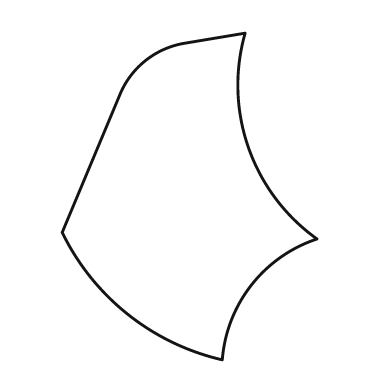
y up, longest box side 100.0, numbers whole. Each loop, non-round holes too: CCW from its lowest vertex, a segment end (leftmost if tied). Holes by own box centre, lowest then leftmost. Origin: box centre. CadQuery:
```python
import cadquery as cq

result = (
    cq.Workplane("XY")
    .moveTo(10.0, -50.0)
    .threePointArc((19.0, -27.0), (39.0, -13.0))
    .threePointArc((18.0, 15.0), (17.0, 50.0))
    .lineTo(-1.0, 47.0)
    .threePointArc((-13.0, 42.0), (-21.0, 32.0))
    .lineTo(-39.0, -11.0)
    .threePointArc((-19.0, -36.0), (10.0, -50.0))
    .close()
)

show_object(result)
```